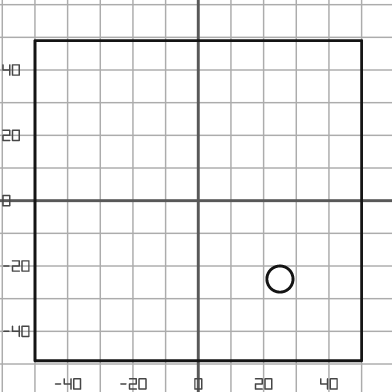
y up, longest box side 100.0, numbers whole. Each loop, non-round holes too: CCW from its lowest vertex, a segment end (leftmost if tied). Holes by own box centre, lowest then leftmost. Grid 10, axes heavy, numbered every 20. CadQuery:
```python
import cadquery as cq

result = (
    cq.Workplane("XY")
    .moveTo(-50.0, -49.0)
    .lineTo(50.0, -49.0)
    .lineTo(50.0, 49.0)
    .lineTo(-50.0, 49.0)
    .close()
    .moveTo(25.0, -24.0)
    .circle(4.0)
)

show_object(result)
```